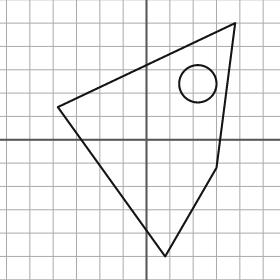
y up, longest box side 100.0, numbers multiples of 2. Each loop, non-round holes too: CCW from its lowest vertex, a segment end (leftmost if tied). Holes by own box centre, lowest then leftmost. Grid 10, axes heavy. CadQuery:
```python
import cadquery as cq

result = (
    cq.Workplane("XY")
    .moveTo(8.0, -50.0)
    .lineTo(30.0, -12.0)
    .lineTo(38.0, 50.0)
    .lineTo(-38.0, 14.0)
    .close()
    .moveTo(22.0, 24.0)
    .circle(8.0)
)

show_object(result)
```